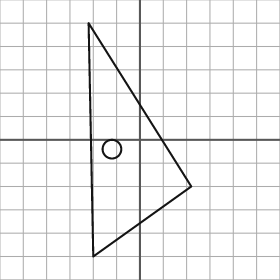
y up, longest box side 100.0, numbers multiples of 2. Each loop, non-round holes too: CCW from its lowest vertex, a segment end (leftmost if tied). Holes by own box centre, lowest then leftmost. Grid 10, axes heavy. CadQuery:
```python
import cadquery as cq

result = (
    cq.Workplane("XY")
    .moveTo(-20.0, -50.0)
    .lineTo(22.0, -20.0)
    .lineTo(-22.0, 50.0)
    .close()
    .moveTo(-12.0, -4.0)
    .circle(4.0)
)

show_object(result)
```